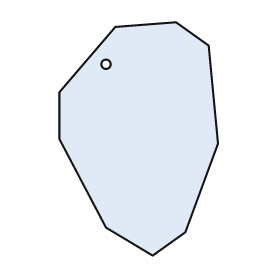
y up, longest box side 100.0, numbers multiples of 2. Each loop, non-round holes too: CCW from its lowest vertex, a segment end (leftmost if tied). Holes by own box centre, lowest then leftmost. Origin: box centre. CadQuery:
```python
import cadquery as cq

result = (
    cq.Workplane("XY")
    .moveTo(6.0, -50.0)
    .lineTo(20.0, -40.0)
    .lineTo(34.0, -2.0)
    .lineTo(30.0, 40.0)
    .lineTo(16.0, 50.0)
    .lineTo(-10.0, 48.0)
    .lineTo(-34.0, 20.0)
    .lineTo(-34.0, 0.0)
    .lineTo(-14.0, -38.0)
    .close()
    .moveTo(-14.0, 32.0)
    .circle(2.0)
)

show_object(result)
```